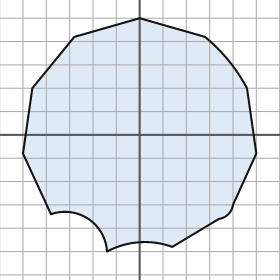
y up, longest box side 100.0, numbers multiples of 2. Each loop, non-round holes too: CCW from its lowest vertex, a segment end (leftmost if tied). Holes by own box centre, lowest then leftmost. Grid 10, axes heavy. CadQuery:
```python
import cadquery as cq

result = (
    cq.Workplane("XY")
    .moveTo(-14.0, -50.0)
    .threePointArc((0.0, -46.0), (14.0, -48.0))
    .lineTo(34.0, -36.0)
    .threePointArc((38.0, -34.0), (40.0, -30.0))
    .lineTo(50.0, -8.0)
    .lineTo(46.0, 20.0)
    .threePointArc((38.0, 32.0), (28.0, 42.0))
    .lineTo(0.0, 50.0)
    .lineTo(-28.0, 42.0)
    .lineTo(-46.0, 20.0)
    .lineTo(-50.0, -8.0)
    .lineTo(-38.0, -34.0)
    .threePointArc((-22.0, -36.0), (-14.0, -50.0))
    .close()
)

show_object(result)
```